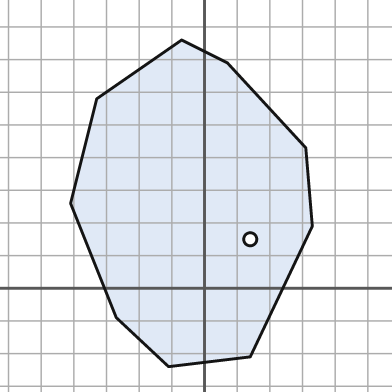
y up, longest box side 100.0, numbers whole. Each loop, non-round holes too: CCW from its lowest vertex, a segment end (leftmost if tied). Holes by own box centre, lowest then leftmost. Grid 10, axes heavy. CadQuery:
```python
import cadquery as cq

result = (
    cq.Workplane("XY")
    .moveTo(-11.0, -24.0)
    .lineTo(14.0, -21.0)
    .lineTo(33.0, 19.0)
    .lineTo(31.0, 43.0)
    .lineTo(7.0, 69.0)
    .lineTo(-7.0, 76.0)
    .lineTo(-33.0, 58.0)
    .lineTo(-41.0, 26.0)
    .lineTo(-27.0, -9.0)
    .close()
    .moveTo(14.0, 15.0)
    .circle(2.0)
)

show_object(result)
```